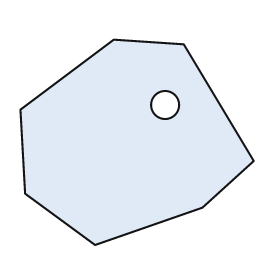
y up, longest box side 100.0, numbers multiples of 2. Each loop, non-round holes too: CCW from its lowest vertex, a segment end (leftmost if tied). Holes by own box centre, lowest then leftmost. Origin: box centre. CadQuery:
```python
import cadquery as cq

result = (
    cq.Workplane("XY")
    .moveTo(-18.0, -44.0)
    .lineTo(28.0, -28.0)
    .lineTo(50.0, -8.0)
    .lineTo(20.0, 42.0)
    .lineTo(-10.0, 44.0)
    .lineTo(-50.0, 14.0)
    .lineTo(-48.0, -22.0)
    .close()
    .moveTo(12.0, 16.0)
    .circle(6.0)
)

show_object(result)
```